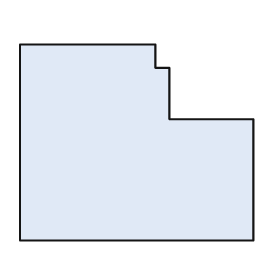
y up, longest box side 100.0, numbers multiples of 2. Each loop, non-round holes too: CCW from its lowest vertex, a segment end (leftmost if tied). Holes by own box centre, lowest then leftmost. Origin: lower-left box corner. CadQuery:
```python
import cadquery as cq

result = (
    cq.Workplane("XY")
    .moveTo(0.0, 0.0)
    .lineTo(100.0, 0.0)
    .lineTo(100.0, 52.0)
    .lineTo(64.0, 52.0)
    .lineTo(64.0, 74.0)
    .lineTo(58.0, 74.0)
    .lineTo(58.0, 84.0)
    .lineTo(0.0, 84.0)
    .close()
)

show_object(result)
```